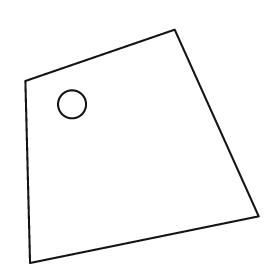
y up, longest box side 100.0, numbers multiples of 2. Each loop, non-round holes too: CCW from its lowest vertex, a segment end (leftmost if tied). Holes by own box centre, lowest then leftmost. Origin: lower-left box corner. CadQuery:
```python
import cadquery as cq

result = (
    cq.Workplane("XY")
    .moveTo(2.0, 0.0)
    .lineTo(100.0, 20.0)
    .lineTo(64.0, 100.0)
    .lineTo(0.0, 78.0)
    .close()
    .moveTo(20.0, 68.0)
    .circle(6.0)
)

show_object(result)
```